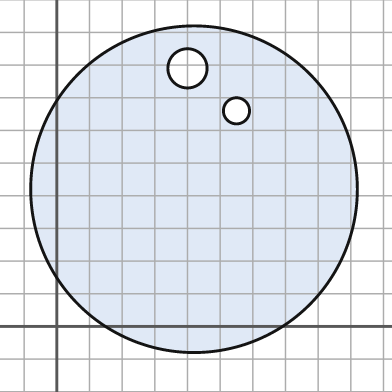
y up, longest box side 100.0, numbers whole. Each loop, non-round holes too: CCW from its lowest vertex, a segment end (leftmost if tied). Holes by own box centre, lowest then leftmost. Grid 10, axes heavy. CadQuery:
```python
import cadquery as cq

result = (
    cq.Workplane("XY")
    .moveTo(42.0, 42.0)
    .circle(50.0)
    .moveTo(55.0, 66.0)
    .circle(4.0)
    .moveTo(40.0, 79.0)
    .circle(6.0)
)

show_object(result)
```